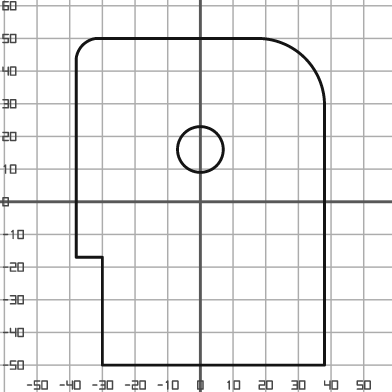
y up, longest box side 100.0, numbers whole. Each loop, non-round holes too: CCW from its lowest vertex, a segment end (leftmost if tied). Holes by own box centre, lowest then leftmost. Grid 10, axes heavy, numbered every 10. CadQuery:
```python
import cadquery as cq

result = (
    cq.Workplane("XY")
    .moveTo(-30.0, -50.0)
    .lineTo(38.0, -50.0)
    .lineTo(38.0, 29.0)
    .threePointArc((32.0, 44.0), (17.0, 50.0))
    .lineTo(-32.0, 50.0)
    .threePointArc((-36.0, 48.0), (-38.0, 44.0))
    .lineTo(-38.0, -17.0)
    .lineTo(-30.0, -17.0)
    .close()
    .moveTo(0.0, 16.0)
    .circle(7.0)
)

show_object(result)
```